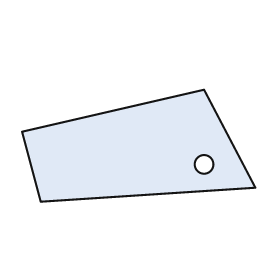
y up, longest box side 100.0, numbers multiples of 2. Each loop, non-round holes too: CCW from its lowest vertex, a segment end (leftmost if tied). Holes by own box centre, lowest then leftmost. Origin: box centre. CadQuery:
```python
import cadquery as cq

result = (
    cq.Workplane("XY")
    .moveTo(-42.0, -24.0)
    .lineTo(50.0, -18.0)
    .lineTo(28.0, 24.0)
    .lineTo(-50.0, 6.0)
    .close()
    .moveTo(28.0, -8.0)
    .circle(4.0)
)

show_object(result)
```